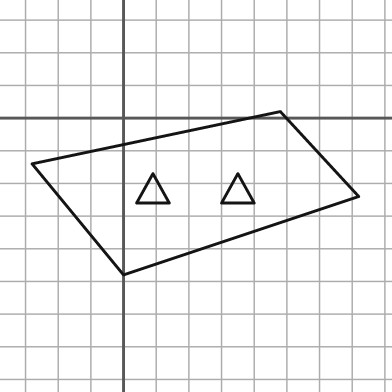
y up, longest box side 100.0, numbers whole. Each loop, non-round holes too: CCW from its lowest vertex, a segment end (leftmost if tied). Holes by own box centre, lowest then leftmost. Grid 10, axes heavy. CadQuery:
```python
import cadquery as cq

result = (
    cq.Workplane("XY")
    .moveTo(0.0, -48.0)
    .lineTo(72.0, -24.0)
    .lineTo(48.0, 2.0)
    .lineTo(-28.0, -14.0)
    .close()
    .moveTo(4.0, -26.0)
    .lineTo(14.0, -26.0)
    .lineTo(9.0, -17.0)
    .close()
    .moveTo(30.0, -26.0)
    .lineTo(40.0, -26.0)
    .lineTo(35.0, -17.0)
    .close()
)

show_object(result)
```